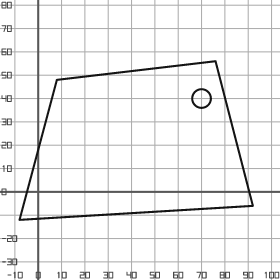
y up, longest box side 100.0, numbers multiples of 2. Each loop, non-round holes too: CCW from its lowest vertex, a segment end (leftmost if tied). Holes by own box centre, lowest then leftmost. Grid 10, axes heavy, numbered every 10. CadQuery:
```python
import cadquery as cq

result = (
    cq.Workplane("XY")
    .moveTo(-8.0, -12.0)
    .lineTo(92.0, -6.0)
    .lineTo(76.0, 56.0)
    .lineTo(8.0, 48.0)
    .close()
    .moveTo(70.0, 40.0)
    .circle(4.0)
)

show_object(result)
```